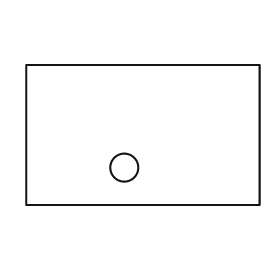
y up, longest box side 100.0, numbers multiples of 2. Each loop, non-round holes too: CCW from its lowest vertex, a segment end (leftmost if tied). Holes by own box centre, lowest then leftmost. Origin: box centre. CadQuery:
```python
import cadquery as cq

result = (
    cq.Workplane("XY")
    .moveTo(-50.0, -30.0)
    .lineTo(50.0, -30.0)
    .lineTo(50.0, 30.0)
    .lineTo(-50.0, 30.0)
    .close()
    .moveTo(-8.0, -14.0)
    .circle(6.0)
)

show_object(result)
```